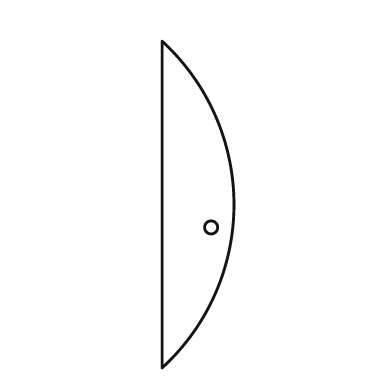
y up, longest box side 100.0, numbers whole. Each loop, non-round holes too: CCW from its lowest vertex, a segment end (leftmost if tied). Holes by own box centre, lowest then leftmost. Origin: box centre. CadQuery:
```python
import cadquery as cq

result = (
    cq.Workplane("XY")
    .moveTo(-11.0, -50.0)
    .threePointArc((11.0, 0.0), (-11.0, 50.0))
    .close()
    .moveTo(4.0, -7.0)
    .circle(2.0)
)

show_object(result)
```